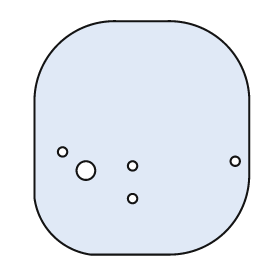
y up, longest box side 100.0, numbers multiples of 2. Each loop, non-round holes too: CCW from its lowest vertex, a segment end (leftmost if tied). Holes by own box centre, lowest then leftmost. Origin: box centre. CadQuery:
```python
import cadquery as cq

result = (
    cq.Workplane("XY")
    .moveTo(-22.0, -50.0)
    .lineTo(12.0, -50.0)
    .threePointArc((36.0, -40.0), (46.0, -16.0))
    .lineTo(46.0, 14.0)
    .threePointArc((36.0, 40.0), (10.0, 50.0))
    .lineTo(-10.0, 50.0)
    .threePointArc((-36.0, 40.0), (-46.0, 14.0))
    .lineTo(-46.0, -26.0)
    .threePointArc((-38.0, -42.0), (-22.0, -50.0))
    .close()
    .moveTo(-4.0, -26.0)
    .circle(2.0)
    .moveTo(-24.0, -14.0)
    .circle(4.0)
    .moveTo(-4.0, -12.0)
    .circle(2.0)
    .moveTo(40.0, -10.0)
    .circle(2.0)
    .moveTo(-34.0, -6.0)
    .circle(2.0)
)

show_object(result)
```